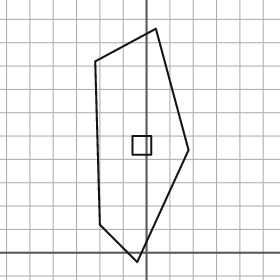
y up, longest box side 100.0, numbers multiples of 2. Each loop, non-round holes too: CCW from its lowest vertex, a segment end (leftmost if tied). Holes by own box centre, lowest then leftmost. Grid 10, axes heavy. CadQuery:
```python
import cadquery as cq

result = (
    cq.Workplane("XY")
    .moveTo(-4.0, -4.0)
    .lineTo(18.0, 44.0)
    .lineTo(4.0, 96.0)
    .lineTo(-22.0, 82.0)
    .lineTo(-20.0, 12.0)
    .close()
    .moveTo(-6.0, 42.0)
    .lineTo(2.0, 42.0)
    .lineTo(2.0, 50.0)
    .lineTo(-6.0, 50.0)
    .close()
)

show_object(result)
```